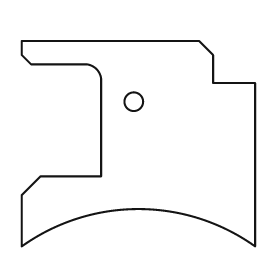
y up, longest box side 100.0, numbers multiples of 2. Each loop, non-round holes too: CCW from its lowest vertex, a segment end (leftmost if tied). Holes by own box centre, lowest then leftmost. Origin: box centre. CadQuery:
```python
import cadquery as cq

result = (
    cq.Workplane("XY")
    .moveTo(-50.0, -44.0)
    .threePointArc((0.0, -28.0), (50.0, -44.0))
    .lineTo(50.0, 26.0)
    .lineTo(32.0, 26.0)
    .lineTo(32.0, 38.0)
    .lineTo(26.0, 44.0)
    .lineTo(-50.0, 44.0)
    .lineTo(-50.0, 38.0)
    .lineTo(-46.0, 34.0)
    .lineTo(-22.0, 34.0)
    .threePointArc((-18.0, 32.0), (-16.0, 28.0))
    .lineTo(-16.0, -14.0)
    .lineTo(-42.0, -14.0)
    .lineTo(-50.0, -22.0)
    .close()
    .moveTo(-2.0, 18.0)
    .circle(4.0)
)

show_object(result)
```